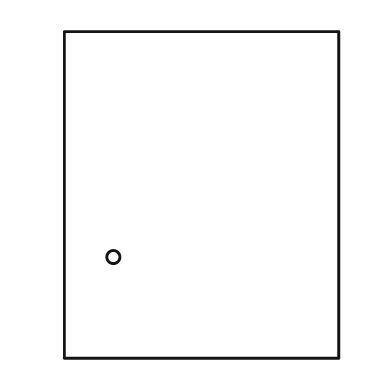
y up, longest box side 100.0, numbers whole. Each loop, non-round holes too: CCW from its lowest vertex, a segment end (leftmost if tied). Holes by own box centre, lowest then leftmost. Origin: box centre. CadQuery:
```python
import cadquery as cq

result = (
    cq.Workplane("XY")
    .moveTo(-42.0, -50.0)
    .lineTo(42.0, -50.0)
    .lineTo(42.0, 50.0)
    .lineTo(-42.0, 50.0)
    .close()
    .moveTo(-27.0, -19.0)
    .circle(2.0)
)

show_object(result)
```